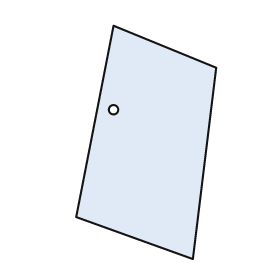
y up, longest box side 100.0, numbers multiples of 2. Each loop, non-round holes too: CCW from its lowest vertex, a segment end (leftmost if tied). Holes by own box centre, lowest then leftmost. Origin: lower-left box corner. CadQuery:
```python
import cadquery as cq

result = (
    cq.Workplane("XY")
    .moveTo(50.0, 0.0)
    .lineTo(60.0, 82.0)
    .lineTo(16.0, 100.0)
    .lineTo(0.0, 18.0)
    .close()
    .moveTo(16.0, 64.0)
    .circle(2.0)
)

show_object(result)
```